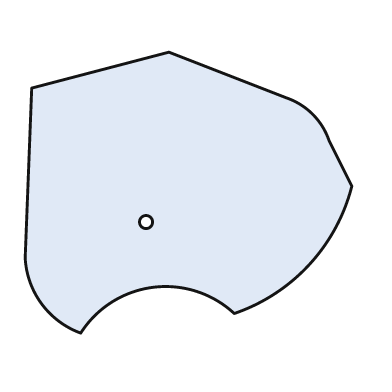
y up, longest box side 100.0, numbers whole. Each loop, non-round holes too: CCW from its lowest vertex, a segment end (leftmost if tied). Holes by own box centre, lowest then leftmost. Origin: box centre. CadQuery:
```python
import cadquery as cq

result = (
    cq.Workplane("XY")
    .moveTo(-33.0, -43.0)
    .threePointArc((-11.0, -29.0), (14.0, -37.0))
    .threePointArc((37.0, -22.0), (50.0, 2.0))
    .lineTo(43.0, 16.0)
    .threePointArc((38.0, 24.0), (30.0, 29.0))
    .lineTo(-6.0, 43.0)
    .lineTo(-48.0, 32.0)
    .lineTo(-50.0, -20.0)
    .threePointArc((-45.0, -34.0), (-33.0, -43.0))
    .close()
    .moveTo(-13.0, -9.0)
    .circle(2.0)
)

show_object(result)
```